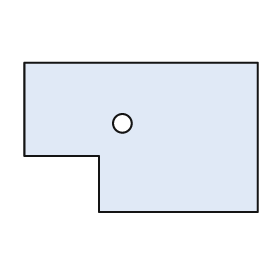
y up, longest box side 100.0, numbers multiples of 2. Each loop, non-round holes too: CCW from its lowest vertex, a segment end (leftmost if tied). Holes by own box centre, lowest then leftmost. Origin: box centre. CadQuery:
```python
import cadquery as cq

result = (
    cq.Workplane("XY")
    .moveTo(-18.0, -32.0)
    .lineTo(50.0, -32.0)
    .lineTo(50.0, 32.0)
    .lineTo(-50.0, 32.0)
    .lineTo(-50.0, -8.0)
    .lineTo(-18.0, -8.0)
    .close()
    .moveTo(-8.0, 6.0)
    .circle(4.0)
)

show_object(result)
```